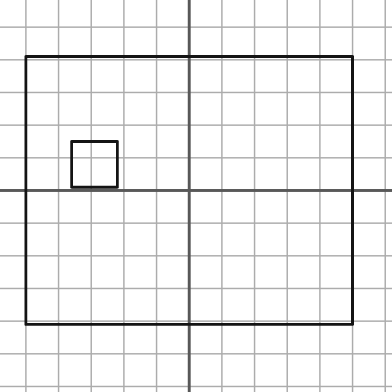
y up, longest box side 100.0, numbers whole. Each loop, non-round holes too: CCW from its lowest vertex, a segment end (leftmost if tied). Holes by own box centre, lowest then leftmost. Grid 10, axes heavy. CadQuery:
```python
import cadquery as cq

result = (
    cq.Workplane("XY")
    .moveTo(-50.0, -41.0)
    .lineTo(50.0, -41.0)
    .lineTo(50.0, 41.0)
    .lineTo(-50.0, 41.0)
    .close()
    .moveTo(-36.0, 1.0)
    .lineTo(-22.0, 1.0)
    .lineTo(-22.0, 15.0)
    .lineTo(-36.0, 15.0)
    .close()
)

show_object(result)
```